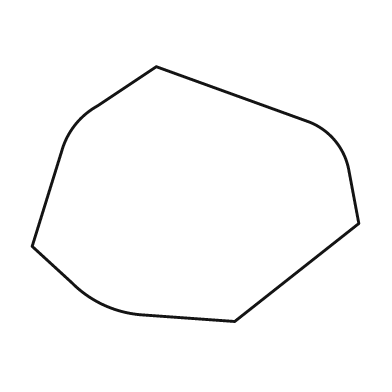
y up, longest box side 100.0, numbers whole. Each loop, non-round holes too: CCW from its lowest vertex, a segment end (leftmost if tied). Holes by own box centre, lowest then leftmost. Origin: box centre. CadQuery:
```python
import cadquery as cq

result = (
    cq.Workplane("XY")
    .moveTo(12.0, -39.0)
    .lineTo(50.0, -9.0)
    .lineTo(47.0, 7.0)
    .threePointArc((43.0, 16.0), (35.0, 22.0))
    .lineTo(-12.0, 39.0)
    .lineTo(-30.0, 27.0)
    .threePointArc((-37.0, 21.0), (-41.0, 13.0))
    .lineTo(-50.0, -16.0)
    .lineTo(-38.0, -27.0)
    .threePointArc((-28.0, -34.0), (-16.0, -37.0))
    .close()
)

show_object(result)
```